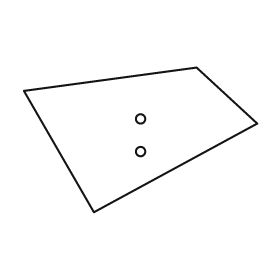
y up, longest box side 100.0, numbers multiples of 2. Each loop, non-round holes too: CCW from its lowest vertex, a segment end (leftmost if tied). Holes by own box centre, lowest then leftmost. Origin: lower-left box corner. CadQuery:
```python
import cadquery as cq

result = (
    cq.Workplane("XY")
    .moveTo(30.0, 0.0)
    .lineTo(100.0, 38.0)
    .lineTo(74.0, 62.0)
    .lineTo(0.0, 52.0)
    .close()
    .moveTo(50.0, 26.0)
    .circle(2.0)
    .moveTo(50.0, 40.0)
    .circle(2.0)
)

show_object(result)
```